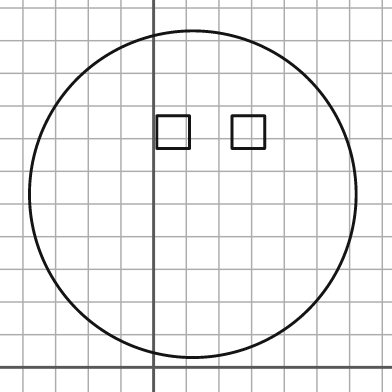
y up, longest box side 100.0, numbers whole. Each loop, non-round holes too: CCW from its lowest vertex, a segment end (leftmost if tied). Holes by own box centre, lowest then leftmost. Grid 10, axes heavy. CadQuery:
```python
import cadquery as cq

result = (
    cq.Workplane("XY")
    .moveTo(12.0, 53.0)
    .circle(50.0)
    .moveTo(1.0, 67.0)
    .lineTo(11.0, 67.0)
    .lineTo(11.0, 77.0)
    .lineTo(1.0, 77.0)
    .close()
    .moveTo(24.0, 67.0)
    .lineTo(34.0, 67.0)
    .lineTo(34.0, 77.0)
    .lineTo(24.0, 77.0)
    .close()
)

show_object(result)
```